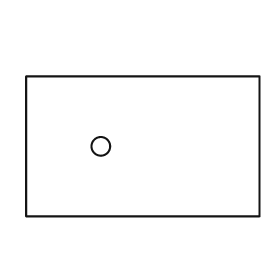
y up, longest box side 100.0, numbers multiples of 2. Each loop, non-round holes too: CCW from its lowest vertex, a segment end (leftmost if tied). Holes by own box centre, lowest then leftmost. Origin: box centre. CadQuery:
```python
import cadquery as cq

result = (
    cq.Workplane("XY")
    .moveTo(-50.0, -30.0)
    .lineTo(50.0, -30.0)
    .lineTo(50.0, 30.0)
    .lineTo(-50.0, 30.0)
    .close()
    .moveTo(-18.0, 0.0)
    .circle(4.0)
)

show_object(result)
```